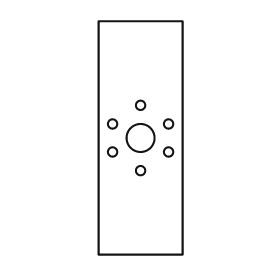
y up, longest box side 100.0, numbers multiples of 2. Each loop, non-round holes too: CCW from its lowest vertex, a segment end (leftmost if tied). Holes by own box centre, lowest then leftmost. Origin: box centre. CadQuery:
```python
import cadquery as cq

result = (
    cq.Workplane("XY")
    .moveTo(-18.0, -50.0)
    .lineTo(18.0, -50.0)
    .lineTo(18.0, 50.0)
    .lineTo(-18.0, 50.0)
    .close()
    .moveTo(0.0, -14.0)
    .circle(2.0)
    .moveTo(-12.0, -6.0)
    .circle(2.0)
    .moveTo(12.0, -6.0)
    .circle(2.0)
    .moveTo(0.0, 0.0)
    .circle(6.0)
    .moveTo(-12.0, 6.0)
    .circle(2.0)
    .moveTo(12.0, 6.0)
    .circle(2.0)
    .moveTo(0.0, 14.0)
    .circle(2.0)
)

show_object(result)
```